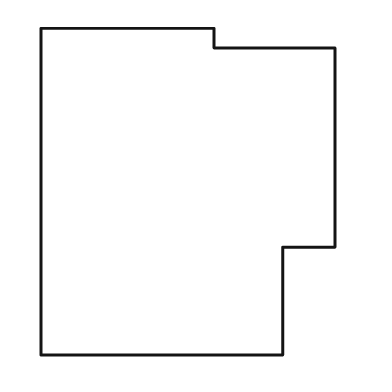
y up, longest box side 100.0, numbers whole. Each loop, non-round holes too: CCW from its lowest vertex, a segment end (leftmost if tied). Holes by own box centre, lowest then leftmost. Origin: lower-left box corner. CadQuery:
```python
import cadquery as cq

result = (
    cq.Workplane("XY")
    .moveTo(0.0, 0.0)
    .lineTo(74.0, 0.0)
    .lineTo(74.0, 33.0)
    .lineTo(90.0, 33.0)
    .lineTo(90.0, 94.0)
    .lineTo(53.0, 94.0)
    .lineTo(53.0, 100.0)
    .lineTo(0.0, 100.0)
    .close()
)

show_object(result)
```